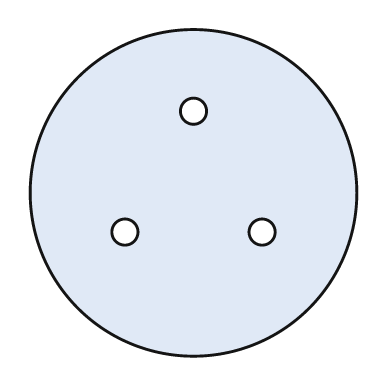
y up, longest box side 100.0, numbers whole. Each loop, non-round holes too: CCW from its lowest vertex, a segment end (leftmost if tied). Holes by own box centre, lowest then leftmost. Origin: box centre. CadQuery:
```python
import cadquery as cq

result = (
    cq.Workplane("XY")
    .moveTo(0.0, 0.0)
    .circle(50.0)
    .moveTo(-21.0, -12.0)
    .circle(4.0)
    .moveTo(21.0, -12.0)
    .circle(4.0)
    .moveTo(0.0, 25.0)
    .circle(4.0)
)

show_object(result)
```